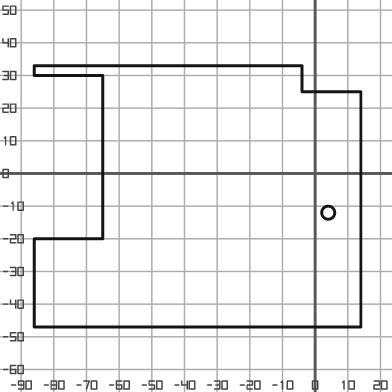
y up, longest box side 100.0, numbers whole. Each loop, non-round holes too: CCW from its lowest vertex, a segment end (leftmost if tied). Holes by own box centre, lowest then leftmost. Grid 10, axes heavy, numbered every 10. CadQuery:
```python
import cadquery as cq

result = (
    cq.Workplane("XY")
    .moveTo(-86.0, -47.0)
    .lineTo(14.0, -47.0)
    .lineTo(14.0, 25.0)
    .lineTo(-4.0, 25.0)
    .lineTo(-4.0, 33.0)
    .lineTo(-86.0, 33.0)
    .lineTo(-86.0, 30.0)
    .lineTo(-65.0, 30.0)
    .lineTo(-65.0, -20.0)
    .lineTo(-86.0, -20.0)
    .close()
    .moveTo(4.0, -12.0)
    .circle(2.0)
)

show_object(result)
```